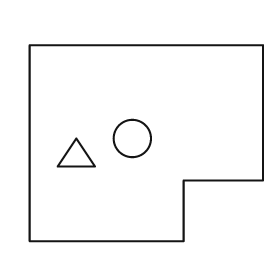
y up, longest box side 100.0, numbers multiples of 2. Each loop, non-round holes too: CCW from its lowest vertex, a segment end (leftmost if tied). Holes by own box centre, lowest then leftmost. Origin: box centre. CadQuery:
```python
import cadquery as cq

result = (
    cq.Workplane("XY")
    .moveTo(-50.0, -42.0)
    .lineTo(16.0, -42.0)
    .lineTo(16.0, -16.0)
    .lineTo(50.0, -16.0)
    .lineTo(50.0, 42.0)
    .lineTo(-50.0, 42.0)
    .close()
    .moveTo(-38.0, -10.0)
    .lineTo(-22.0, -10.0)
    .lineTo(-30.0, 2.0)
    .close()
    .moveTo(-6.0, 2.0)
    .circle(8.0)
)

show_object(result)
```